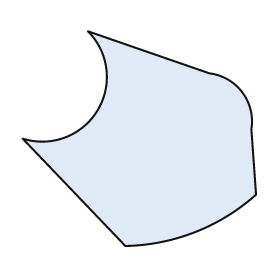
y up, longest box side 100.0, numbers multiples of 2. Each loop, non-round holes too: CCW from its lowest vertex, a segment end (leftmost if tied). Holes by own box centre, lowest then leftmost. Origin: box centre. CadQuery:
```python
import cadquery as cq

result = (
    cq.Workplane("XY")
    .moveTo(-6.0, -46.0)
    .threePointArc((24.0, -40.0), (50.0, -24.0))
    .lineTo(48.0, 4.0)
    .threePointArc((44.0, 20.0), (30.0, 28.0))
    .lineTo(-22.0, 46.0)
    .threePointArc((-18.0, 12.0), (-50.0, 0.0))
    .close()
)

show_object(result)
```